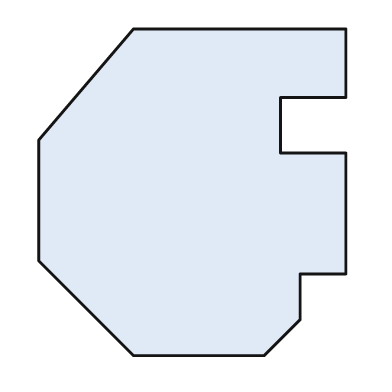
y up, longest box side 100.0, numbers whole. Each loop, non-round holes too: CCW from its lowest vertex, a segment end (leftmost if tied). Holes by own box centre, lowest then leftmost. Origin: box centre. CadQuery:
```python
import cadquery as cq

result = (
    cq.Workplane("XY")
    .moveTo(-18.0, -50.0)
    .lineTo(22.0, -50.0)
    .lineTo(33.0, -39.0)
    .lineTo(33.0, -25.0)
    .lineTo(47.0, -25.0)
    .lineTo(47.0, 12.0)
    .lineTo(27.0, 12.0)
    .lineTo(27.0, 29.0)
    .lineTo(47.0, 29.0)
    .lineTo(47.0, 50.0)
    .lineTo(-18.0, 50.0)
    .lineTo(-47.0, 16.0)
    .lineTo(-47.0, -21.0)
    .close()
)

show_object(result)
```